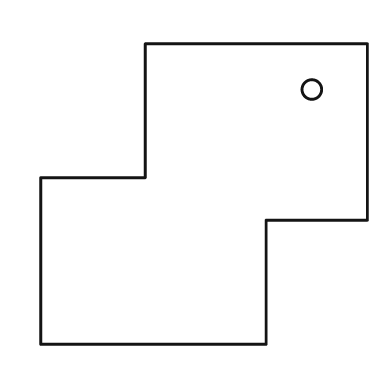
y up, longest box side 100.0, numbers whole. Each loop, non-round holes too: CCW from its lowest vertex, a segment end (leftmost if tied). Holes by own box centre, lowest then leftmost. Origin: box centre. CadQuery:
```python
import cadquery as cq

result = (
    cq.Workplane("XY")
    .moveTo(-50.0, -46.0)
    .lineTo(19.0, -46.0)
    .lineTo(19.0, -8.0)
    .lineTo(50.0, -8.0)
    .lineTo(50.0, 46.0)
    .lineTo(-18.0, 46.0)
    .lineTo(-18.0, 5.0)
    .lineTo(-50.0, 5.0)
    .close()
    .moveTo(33.0, 32.0)
    .circle(3.0)
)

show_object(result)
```